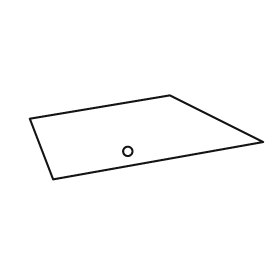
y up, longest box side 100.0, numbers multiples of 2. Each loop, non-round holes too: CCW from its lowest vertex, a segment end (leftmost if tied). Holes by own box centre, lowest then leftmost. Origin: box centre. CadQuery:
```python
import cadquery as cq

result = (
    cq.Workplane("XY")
    .moveTo(-40.0, -18.0)
    .lineTo(50.0, -2.0)
    .lineTo(10.0, 18.0)
    .lineTo(-50.0, 8.0)
    .close()
    .moveTo(-8.0, -6.0)
    .circle(2.0)
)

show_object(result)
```